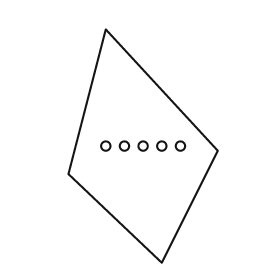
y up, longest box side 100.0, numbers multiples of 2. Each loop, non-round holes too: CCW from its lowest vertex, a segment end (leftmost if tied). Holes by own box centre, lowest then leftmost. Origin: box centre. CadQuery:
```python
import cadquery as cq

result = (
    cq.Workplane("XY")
    .moveTo(8.0, -50.0)
    .lineTo(32.0, -2.0)
    .lineTo(-16.0, 50.0)
    .lineTo(-32.0, -12.0)
    .close()
    .moveTo(-16.0, 0.0)
    .circle(2.0)
    .moveTo(-8.0, 0.0)
    .circle(2.0)
    .moveTo(0.0, 0.0)
    .circle(2.0)
    .moveTo(8.0, 0.0)
    .circle(2.0)
    .moveTo(16.0, 0.0)
    .circle(2.0)
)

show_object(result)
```